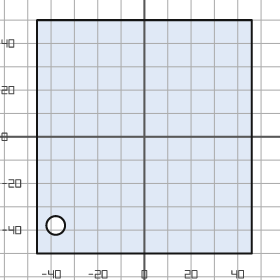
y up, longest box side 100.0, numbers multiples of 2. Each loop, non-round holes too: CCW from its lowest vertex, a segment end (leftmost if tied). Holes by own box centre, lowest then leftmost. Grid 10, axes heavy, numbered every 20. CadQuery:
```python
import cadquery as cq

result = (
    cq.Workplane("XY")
    .moveTo(-46.0, -50.0)
    .lineTo(46.0, -50.0)
    .lineTo(46.0, 50.0)
    .lineTo(-46.0, 50.0)
    .close()
    .moveTo(-38.0, -38.0)
    .circle(4.0)
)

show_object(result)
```